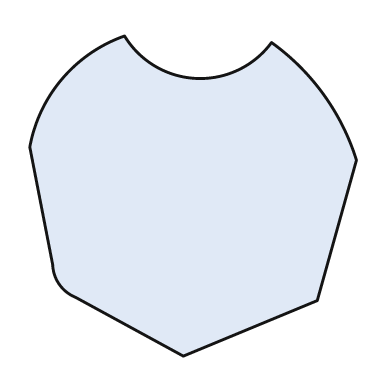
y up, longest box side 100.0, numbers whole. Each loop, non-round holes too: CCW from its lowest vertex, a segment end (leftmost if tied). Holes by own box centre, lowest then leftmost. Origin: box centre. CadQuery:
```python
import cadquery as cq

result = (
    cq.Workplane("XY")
    .moveTo(-3.0, -49.0)
    .lineTo(38.0, -32.0)
    .lineTo(50.0, 11.0)
    .threePointArc((40.0, 31.0), (24.0, 47.0))
    .threePointArc((1.0, 36.0), (-21.0, 49.0))
    .threePointArc((-40.0, 36.0), (-50.0, 15.0))
    .lineTo(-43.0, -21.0)
    .threePointArc((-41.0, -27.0), (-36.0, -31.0))
    .close()
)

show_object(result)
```